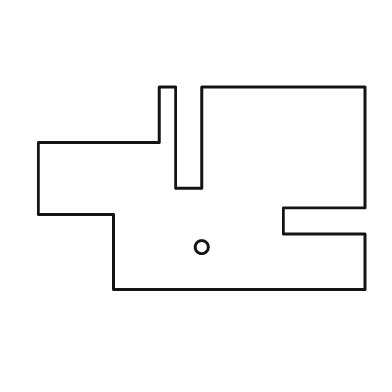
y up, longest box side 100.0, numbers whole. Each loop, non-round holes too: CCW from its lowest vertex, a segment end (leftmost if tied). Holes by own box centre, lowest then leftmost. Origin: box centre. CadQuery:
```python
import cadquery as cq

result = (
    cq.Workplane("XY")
    .moveTo(-27.0, -31.0)
    .lineTo(50.0, -31.0)
    .lineTo(50.0, -14.0)
    .lineTo(25.0, -14.0)
    .lineTo(25.0, -6.0)
    .lineTo(50.0, -6.0)
    .lineTo(50.0, 31.0)
    .lineTo(0.0, 31.0)
    .lineTo(0.0, 0.0)
    .lineTo(-8.0, 0.0)
    .lineTo(-8.0, 31.0)
    .lineTo(-13.0, 31.0)
    .lineTo(-13.0, 14.0)
    .lineTo(-50.0, 14.0)
    .lineTo(-50.0, -8.0)
    .lineTo(-27.0, -8.0)
    .close()
    .moveTo(0.0, -18.0)
    .circle(2.0)
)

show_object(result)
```